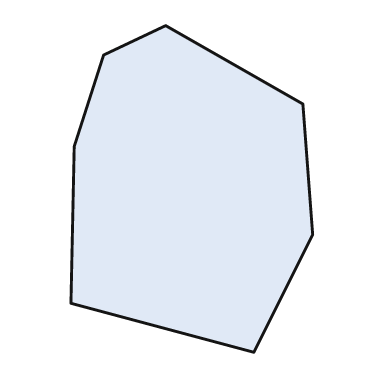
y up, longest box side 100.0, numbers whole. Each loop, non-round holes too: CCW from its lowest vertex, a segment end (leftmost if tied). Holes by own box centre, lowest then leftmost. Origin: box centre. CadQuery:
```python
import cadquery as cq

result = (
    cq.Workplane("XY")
    .moveTo(19.0, -50.0)
    .lineTo(37.0, -14.0)
    .lineTo(34.0, 26.0)
    .lineTo(-8.0, 50.0)
    .lineTo(-27.0, 41.0)
    .lineTo(-36.0, 13.0)
    .lineTo(-37.0, -35.0)
    .close()
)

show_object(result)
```